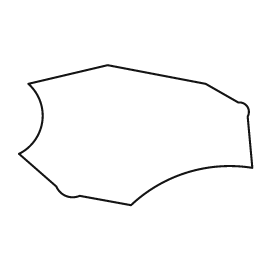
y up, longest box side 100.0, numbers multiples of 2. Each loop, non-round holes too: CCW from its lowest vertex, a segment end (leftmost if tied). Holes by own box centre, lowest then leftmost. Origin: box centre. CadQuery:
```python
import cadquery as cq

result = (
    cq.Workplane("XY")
    .moveTo(-2.0, -30.0)
    .threePointArc((22.0, -16.0), (50.0, -14.0))
    .lineTo(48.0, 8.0)
    .threePointArc((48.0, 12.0), (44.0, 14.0))
    .lineTo(30.0, 22.0)
    .lineTo(-12.0, 30.0)
    .lineTo(-46.0, 22.0)
    .threePointArc((-40.0, 6.0), (-50.0, -8.0))
    .lineTo(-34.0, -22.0)
    .threePointArc((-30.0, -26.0), (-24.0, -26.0))
    .close()
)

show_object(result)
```